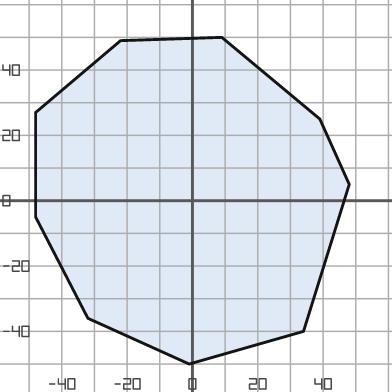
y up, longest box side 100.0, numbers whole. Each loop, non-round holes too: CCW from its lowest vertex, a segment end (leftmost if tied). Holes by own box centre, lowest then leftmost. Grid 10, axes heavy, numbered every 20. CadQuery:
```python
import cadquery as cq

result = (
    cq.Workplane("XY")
    .moveTo(-1.0, -50.0)
    .lineTo(34.0, -40.0)
    .lineTo(48.0, 5.0)
    .lineTo(39.0, 25.0)
    .lineTo(9.0, 50.0)
    .lineTo(-22.0, 49.0)
    .lineTo(-48.0, 27.0)
    .lineTo(-48.0, -5.0)
    .lineTo(-32.0, -36.0)
    .close()
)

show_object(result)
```